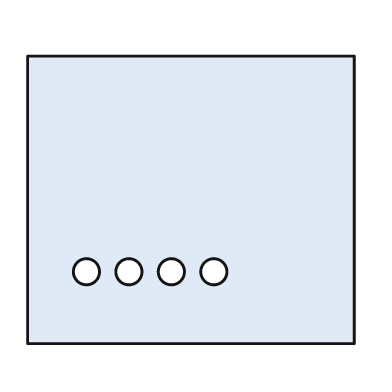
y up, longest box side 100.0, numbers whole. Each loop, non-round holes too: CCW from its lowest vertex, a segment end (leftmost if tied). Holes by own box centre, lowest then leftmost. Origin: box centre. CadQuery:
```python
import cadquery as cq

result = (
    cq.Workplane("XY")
    .moveTo(-50.0, -44.0)
    .lineTo(50.0, -44.0)
    .lineTo(50.0, 44.0)
    .lineTo(-50.0, 44.0)
    .close()
    .moveTo(-32.0, -22.0)
    .circle(4.0)
    .moveTo(-19.0, -22.0)
    .circle(4.0)
    .moveTo(-6.0, -22.0)
    .circle(4.0)
    .moveTo(7.0, -22.0)
    .circle(4.0)
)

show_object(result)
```